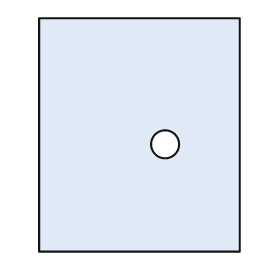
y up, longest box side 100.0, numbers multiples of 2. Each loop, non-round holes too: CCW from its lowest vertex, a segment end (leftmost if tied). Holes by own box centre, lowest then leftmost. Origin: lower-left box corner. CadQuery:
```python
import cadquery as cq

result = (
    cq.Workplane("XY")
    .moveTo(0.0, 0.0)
    .lineTo(86.0, 0.0)
    .lineTo(86.0, 100.0)
    .lineTo(0.0, 100.0)
    .close()
    .moveTo(54.0, 46.0)
    .circle(6.0)
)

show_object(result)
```